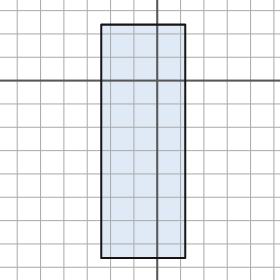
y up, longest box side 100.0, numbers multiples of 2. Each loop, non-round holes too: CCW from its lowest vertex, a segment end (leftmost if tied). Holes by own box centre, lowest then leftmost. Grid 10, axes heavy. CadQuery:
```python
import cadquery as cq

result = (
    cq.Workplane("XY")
    .moveTo(-24.0, -76.0)
    .lineTo(12.0, -76.0)
    .lineTo(12.0, 24.0)
    .lineTo(-24.0, 24.0)
    .close()
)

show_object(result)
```